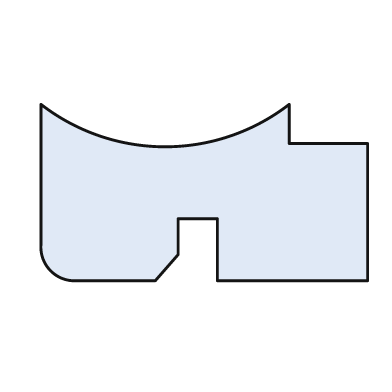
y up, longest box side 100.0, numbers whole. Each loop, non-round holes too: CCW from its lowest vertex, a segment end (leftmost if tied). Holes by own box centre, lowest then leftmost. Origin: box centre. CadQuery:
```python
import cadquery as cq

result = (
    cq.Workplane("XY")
    .moveTo(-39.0, -27.0)
    .lineTo(-15.0, -27.0)
    .lineTo(-8.0, -19.0)
    .lineTo(-8.0, -8.0)
    .lineTo(4.0, -8.0)
    .lineTo(4.0, -27.0)
    .lineTo(50.0, -27.0)
    .lineTo(50.0, 15.0)
    .lineTo(26.0, 15.0)
    .lineTo(26.0, 27.0)
    .threePointArc((-12.0, 14.0), (-50.0, 27.0))
    .lineTo(-50.0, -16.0)
    .threePointArc((-47.0, -24.0), (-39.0, -27.0))
    .close()
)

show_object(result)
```